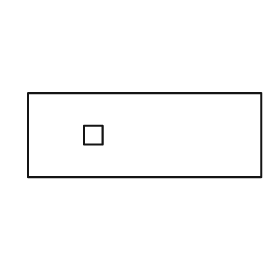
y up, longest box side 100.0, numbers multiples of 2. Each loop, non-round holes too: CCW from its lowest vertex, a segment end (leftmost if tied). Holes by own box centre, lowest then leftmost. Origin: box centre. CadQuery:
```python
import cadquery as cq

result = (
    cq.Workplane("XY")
    .moveTo(-50.0, -18.0)
    .lineTo(50.0, -18.0)
    .lineTo(50.0, 18.0)
    .lineTo(-50.0, 18.0)
    .close()
    .moveTo(-26.0, -4.0)
    .lineTo(-18.0, -4.0)
    .lineTo(-18.0, 4.0)
    .lineTo(-26.0, 4.0)
    .close()
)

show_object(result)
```